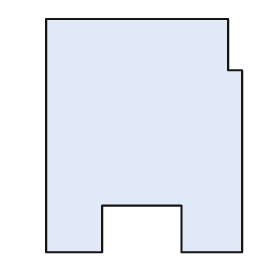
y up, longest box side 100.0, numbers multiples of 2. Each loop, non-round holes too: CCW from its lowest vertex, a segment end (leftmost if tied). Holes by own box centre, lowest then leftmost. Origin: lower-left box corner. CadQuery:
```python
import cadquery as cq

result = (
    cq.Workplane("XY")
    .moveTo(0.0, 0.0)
    .lineTo(24.0, 0.0)
    .lineTo(24.0, 20.0)
    .lineTo(58.0, 20.0)
    .lineTo(58.0, 0.0)
    .lineTo(84.0, 0.0)
    .lineTo(84.0, 78.0)
    .lineTo(78.0, 78.0)
    .lineTo(78.0, 100.0)
    .lineTo(0.0, 100.0)
    .close()
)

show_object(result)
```